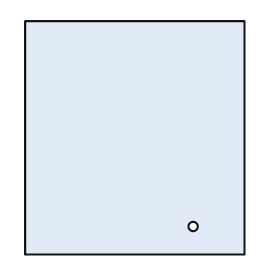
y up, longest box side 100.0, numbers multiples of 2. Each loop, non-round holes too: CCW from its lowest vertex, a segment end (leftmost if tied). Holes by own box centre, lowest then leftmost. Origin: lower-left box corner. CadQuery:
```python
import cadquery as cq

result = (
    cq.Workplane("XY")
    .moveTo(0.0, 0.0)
    .lineTo(94.0, 0.0)
    .lineTo(94.0, 100.0)
    .lineTo(0.0, 100.0)
    .close()
    .moveTo(72.0, 12.0)
    .circle(2.0)
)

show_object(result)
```